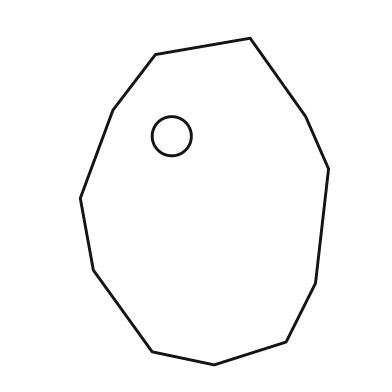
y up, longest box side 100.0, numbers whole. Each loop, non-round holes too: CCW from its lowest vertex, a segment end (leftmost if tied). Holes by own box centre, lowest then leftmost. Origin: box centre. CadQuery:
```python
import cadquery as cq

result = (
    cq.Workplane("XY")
    .moveTo(3.0, -50.0)
    .lineTo(25.0, -43.0)
    .lineTo(34.0, -25.0)
    .lineTo(38.0, 10.0)
    .lineTo(31.0, 26.0)
    .lineTo(14.0, 50.0)
    .lineTo(-15.0, 45.0)
    .lineTo(-28.0, 28.0)
    .lineTo(-38.0, 1.0)
    .lineTo(-34.0, -21.0)
    .lineTo(-16.0, -46.0)
    .close()
    .moveTo(-10.0, 20.0)
    .circle(6.0)
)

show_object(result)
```